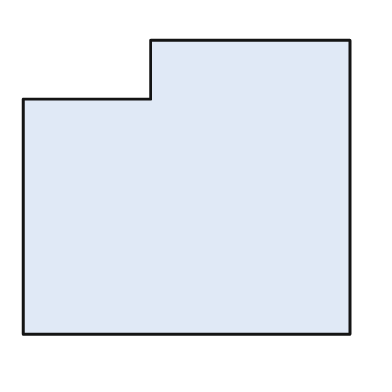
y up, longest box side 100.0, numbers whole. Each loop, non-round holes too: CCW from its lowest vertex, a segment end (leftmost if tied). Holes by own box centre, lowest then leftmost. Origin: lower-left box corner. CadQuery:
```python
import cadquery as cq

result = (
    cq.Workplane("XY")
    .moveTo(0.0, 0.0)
    .lineTo(100.0, 0.0)
    .lineTo(100.0, 90.0)
    .lineTo(39.0, 90.0)
    .lineTo(39.0, 72.0)
    .lineTo(0.0, 72.0)
    .close()
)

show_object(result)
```